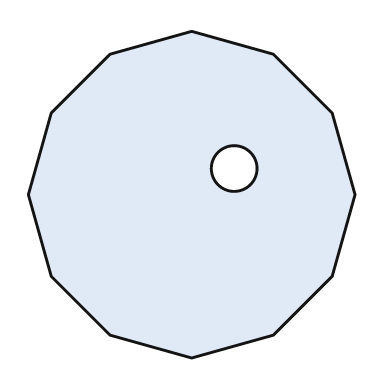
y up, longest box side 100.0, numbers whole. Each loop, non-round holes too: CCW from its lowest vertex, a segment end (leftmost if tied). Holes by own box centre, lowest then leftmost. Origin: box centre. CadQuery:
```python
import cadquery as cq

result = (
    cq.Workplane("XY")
    .moveTo(0.0, -50.0)
    .lineTo(25.0, -43.0)
    .lineTo(43.0, -25.0)
    .lineTo(50.0, 0.0)
    .lineTo(43.0, 25.0)
    .lineTo(25.0, 43.0)
    .lineTo(0.0, 50.0)
    .lineTo(-25.0, 43.0)
    .lineTo(-43.0, 25.0)
    .lineTo(-50.0, 0.0)
    .lineTo(-43.0, -25.0)
    .lineTo(-25.0, -43.0)
    .close()
    .moveTo(13.0, 8.0)
    .circle(7.0)
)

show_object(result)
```